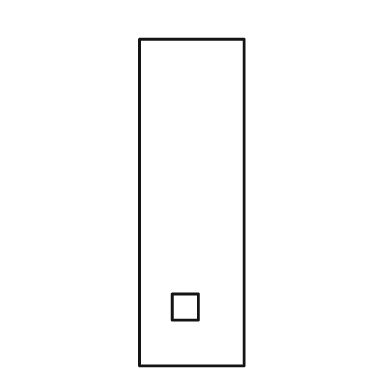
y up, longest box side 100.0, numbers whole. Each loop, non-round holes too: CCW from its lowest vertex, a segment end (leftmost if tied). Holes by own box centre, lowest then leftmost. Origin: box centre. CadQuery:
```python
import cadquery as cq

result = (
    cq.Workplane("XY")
    .moveTo(-16.0, -50.0)
    .lineTo(16.0, -50.0)
    .lineTo(16.0, 50.0)
    .lineTo(-16.0, 50.0)
    .close()
    .moveTo(-6.0, -36.0)
    .lineTo(2.0, -36.0)
    .lineTo(2.0, -28.0)
    .lineTo(-6.0, -28.0)
    .close()
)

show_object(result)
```